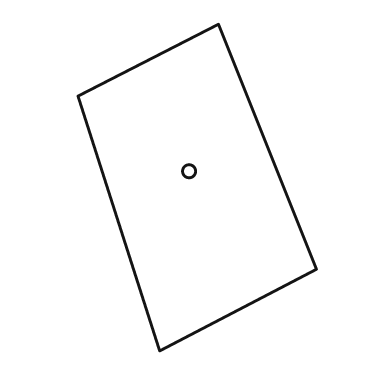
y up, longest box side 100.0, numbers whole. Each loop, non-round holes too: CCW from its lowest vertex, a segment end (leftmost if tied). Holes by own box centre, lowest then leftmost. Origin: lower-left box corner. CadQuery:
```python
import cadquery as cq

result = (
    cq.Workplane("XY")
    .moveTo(25.0, 0.0)
    .lineTo(73.0, 25.0)
    .lineTo(43.0, 100.0)
    .lineTo(0.0, 78.0)
    .close()
    .moveTo(34.0, 55.0)
    .circle(2.0)
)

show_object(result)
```